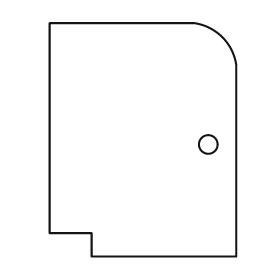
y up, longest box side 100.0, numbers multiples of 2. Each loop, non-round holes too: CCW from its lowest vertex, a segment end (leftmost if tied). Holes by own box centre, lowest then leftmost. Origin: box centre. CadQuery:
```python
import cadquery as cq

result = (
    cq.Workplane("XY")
    .moveTo(-22.0, -50.0)
    .lineTo(40.0, -50.0)
    .lineTo(40.0, 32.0)
    .threePointArc((34.0, 44.0), (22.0, 50.0))
    .lineTo(-40.0, 50.0)
    .lineTo(-40.0, -40.0)
    .lineTo(-22.0, -40.0)
    .close()
    .moveTo(28.0, -2.0)
    .circle(4.0)
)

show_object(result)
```